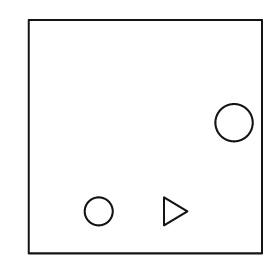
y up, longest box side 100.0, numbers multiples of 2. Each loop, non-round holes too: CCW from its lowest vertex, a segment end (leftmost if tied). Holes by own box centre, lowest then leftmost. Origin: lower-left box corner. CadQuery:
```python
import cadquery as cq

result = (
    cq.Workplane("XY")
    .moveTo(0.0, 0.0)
    .lineTo(100.0, 0.0)
    .lineTo(100.0, 100.0)
    .lineTo(0.0, 100.0)
    .close()
    .moveTo(30.0, 18.0)
    .circle(6.0)
    .moveTo(58.0, 12.0)
    .lineTo(68.0, 18.0)
    .lineTo(58.0, 24.0)
    .close()
    .moveTo(88.0, 56.0)
    .circle(8.0)
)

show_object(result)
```